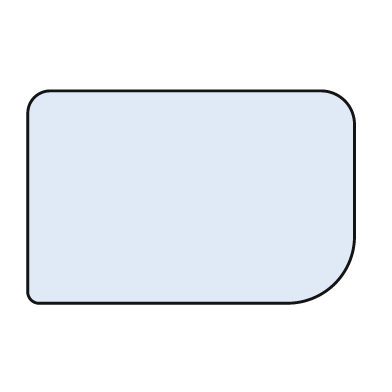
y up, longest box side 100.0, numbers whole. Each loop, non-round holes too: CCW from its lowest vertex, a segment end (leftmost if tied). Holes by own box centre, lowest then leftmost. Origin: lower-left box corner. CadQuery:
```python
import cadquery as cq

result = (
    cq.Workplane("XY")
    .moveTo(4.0, 0.0)
    .lineTo(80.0, 0.0)
    .threePointArc((94.0, 6.0), (100.0, 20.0))
    .lineTo(100.0, 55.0)
    .threePointArc((97.0, 62.0), (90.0, 65.0))
    .lineTo(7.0, 65.0)
    .threePointArc((2.0, 63.0), (0.0, 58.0))
    .lineTo(0.0, 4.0)
    .threePointArc((1.0, 1.0), (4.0, 0.0))
    .close()
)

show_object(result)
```